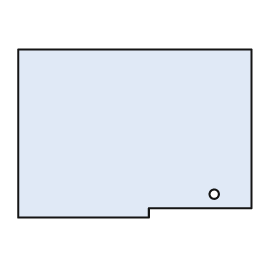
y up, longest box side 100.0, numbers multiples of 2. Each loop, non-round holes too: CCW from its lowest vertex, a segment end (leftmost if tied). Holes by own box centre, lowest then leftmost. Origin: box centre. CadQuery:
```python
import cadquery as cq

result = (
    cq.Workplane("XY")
    .moveTo(-50.0, -36.0)
    .lineTo(6.0, -36.0)
    .lineTo(6.0, -32.0)
    .lineTo(50.0, -32.0)
    .lineTo(50.0, 36.0)
    .lineTo(-50.0, 36.0)
    .close()
    .moveTo(34.0, -26.0)
    .circle(2.0)
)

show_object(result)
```